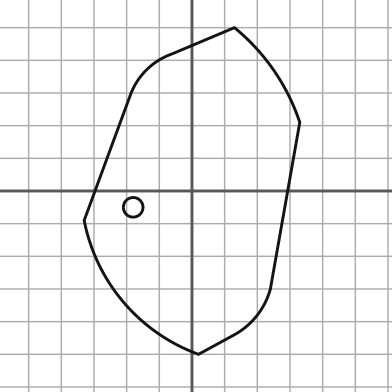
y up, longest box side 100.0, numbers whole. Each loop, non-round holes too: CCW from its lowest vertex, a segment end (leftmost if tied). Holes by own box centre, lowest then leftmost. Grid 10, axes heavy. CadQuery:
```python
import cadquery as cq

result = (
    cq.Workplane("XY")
    .moveTo(2.0, -50.0)
    .lineTo(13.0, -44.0)
    .threePointArc((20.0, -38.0), (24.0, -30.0))
    .lineTo(33.0, 21.0)
    .threePointArc((25.0, 37.0), (13.0, 50.0))
    .lineTo(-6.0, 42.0)
    .threePointArc((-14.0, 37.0), (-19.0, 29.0))
    .lineTo(-33.0, -9.0)
    .threePointArc((-21.0, -34.0), (2.0, -50.0))
    .close()
    .moveTo(-18.0, -5.0)
    .circle(3.0)
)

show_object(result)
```